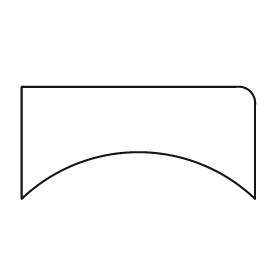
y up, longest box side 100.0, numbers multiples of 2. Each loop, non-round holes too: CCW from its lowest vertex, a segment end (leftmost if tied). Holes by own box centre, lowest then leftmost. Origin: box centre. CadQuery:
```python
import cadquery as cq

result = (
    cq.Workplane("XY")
    .moveTo(-50.0, -24.0)
    .threePointArc((0.0, -4.0), (50.0, -24.0))
    .lineTo(50.0, 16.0)
    .threePointArc((48.0, 22.0), (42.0, 24.0))
    .lineTo(-50.0, 24.0)
    .close()
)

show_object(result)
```